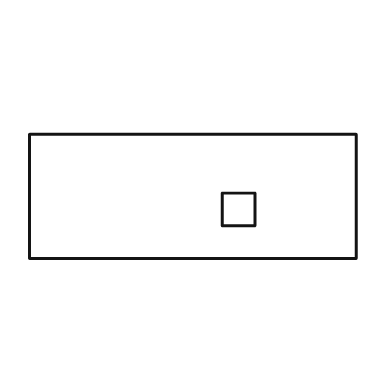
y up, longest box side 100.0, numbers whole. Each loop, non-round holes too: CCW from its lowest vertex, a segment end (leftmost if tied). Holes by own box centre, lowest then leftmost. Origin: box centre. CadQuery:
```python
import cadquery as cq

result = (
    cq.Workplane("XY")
    .moveTo(-50.0, -19.0)
    .lineTo(50.0, -19.0)
    .lineTo(50.0, 19.0)
    .lineTo(-50.0, 19.0)
    .close()
    .moveTo(9.0, -9.0)
    .lineTo(19.0, -9.0)
    .lineTo(19.0, 1.0)
    .lineTo(9.0, 1.0)
    .close()
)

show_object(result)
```